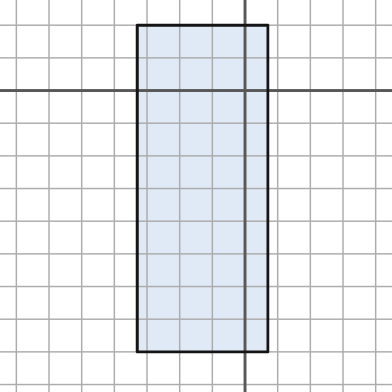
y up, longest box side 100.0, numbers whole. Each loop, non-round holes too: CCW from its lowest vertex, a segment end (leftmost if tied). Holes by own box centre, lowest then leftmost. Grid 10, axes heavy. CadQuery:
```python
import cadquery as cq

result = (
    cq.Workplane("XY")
    .moveTo(-33.0, -80.0)
    .lineTo(7.0, -80.0)
    .lineTo(7.0, 20.0)
    .lineTo(-33.0, 20.0)
    .close()
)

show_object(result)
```